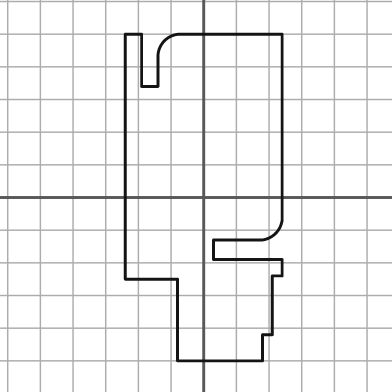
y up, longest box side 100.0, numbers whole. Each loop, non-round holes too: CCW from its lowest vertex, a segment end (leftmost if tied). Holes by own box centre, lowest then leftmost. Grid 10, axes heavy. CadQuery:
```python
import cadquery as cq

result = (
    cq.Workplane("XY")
    .moveTo(-8.0, -50.0)
    .lineTo(18.0, -50.0)
    .lineTo(18.0, -42.0)
    .lineTo(21.0, -42.0)
    .lineTo(21.0, -24.0)
    .lineTo(24.0, -24.0)
    .lineTo(24.0, -19.0)
    .lineTo(3.0, -19.0)
    .lineTo(3.0, -13.0)
    .lineTo(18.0, -13.0)
    .threePointArc((22.0, -11.0), (24.0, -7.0))
    .lineTo(24.0, 50.0)
    .lineTo(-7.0, 50.0)
    .threePointArc((-12.0, 48.0), (-14.0, 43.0))
    .lineTo(-14.0, 34.0)
    .lineTo(-19.0, 34.0)
    .lineTo(-19.0, 50.0)
    .lineTo(-24.0, 50.0)
    .lineTo(-24.0, -25.0)
    .lineTo(-8.0, -25.0)
    .close()
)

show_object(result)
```